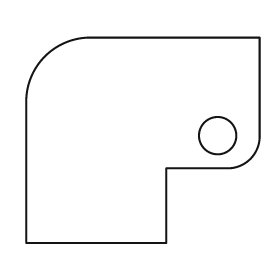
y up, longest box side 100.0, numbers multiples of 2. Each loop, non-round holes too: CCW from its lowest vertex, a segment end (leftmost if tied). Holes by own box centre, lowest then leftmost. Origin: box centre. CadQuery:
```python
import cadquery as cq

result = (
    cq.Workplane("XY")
    .moveTo(-50.0, -44.0)
    .lineTo(10.0, -44.0)
    .lineTo(10.0, -12.0)
    .lineTo(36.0, -12.0)
    .threePointArc((46.0, -8.0), (50.0, 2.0))
    .lineTo(50.0, 44.0)
    .lineTo(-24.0, 44.0)
    .threePointArc((-42.0, 36.0), (-50.0, 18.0))
    .close()
    .moveTo(32.0, 2.0)
    .circle(8.0)
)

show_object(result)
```